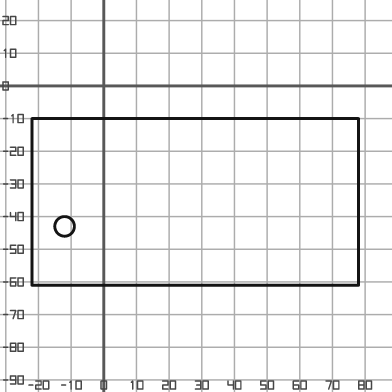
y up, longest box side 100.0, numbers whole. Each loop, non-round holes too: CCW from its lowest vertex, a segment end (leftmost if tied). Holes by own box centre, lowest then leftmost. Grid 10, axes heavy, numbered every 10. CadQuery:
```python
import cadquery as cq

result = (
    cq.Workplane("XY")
    .moveTo(-22.0, -61.0)
    .lineTo(78.0, -61.0)
    .lineTo(78.0, -10.0)
    .lineTo(-22.0, -10.0)
    .close()
    .moveTo(-12.0, -43.0)
    .circle(3.0)
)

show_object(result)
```